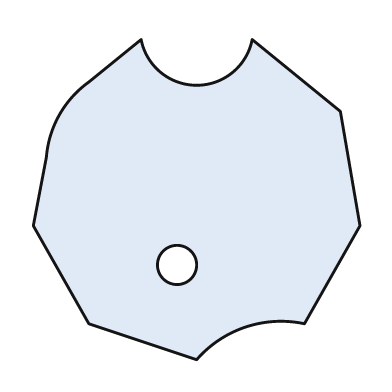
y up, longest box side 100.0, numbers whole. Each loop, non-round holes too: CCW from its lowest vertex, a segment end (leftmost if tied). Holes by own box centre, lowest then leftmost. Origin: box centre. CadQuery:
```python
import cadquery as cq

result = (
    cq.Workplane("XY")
    .moveTo(0.0, -49.0)
    .threePointArc((15.0, -39.0), (33.0, -38.0))
    .lineTo(50.0, -8.0)
    .lineTo(44.0, 27.0)
    .lineTo(17.0, 49.0)
    .threePointArc((0.0, 35.0), (-17.0, 49.0))
    .lineTo(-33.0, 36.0)
    .threePointArc((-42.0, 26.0), (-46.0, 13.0))
    .lineTo(-50.0, -8.0)
    .lineTo(-33.0, -38.0)
    .close()
    .moveTo(-6.0, -20.0)
    .circle(6.0)
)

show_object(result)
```